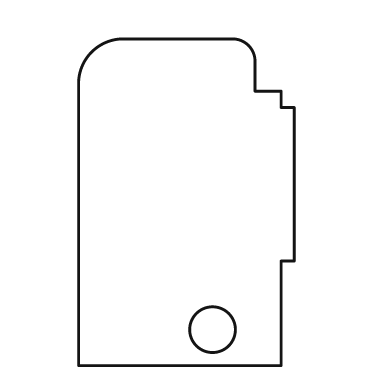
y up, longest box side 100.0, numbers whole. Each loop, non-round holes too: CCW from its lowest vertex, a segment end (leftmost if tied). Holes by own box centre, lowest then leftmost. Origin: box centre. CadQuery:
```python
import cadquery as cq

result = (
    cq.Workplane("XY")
    .moveTo(-33.0, -50.0)
    .lineTo(29.0, -50.0)
    .lineTo(29.0, -18.0)
    .lineTo(33.0, -18.0)
    .lineTo(33.0, 29.0)
    .lineTo(29.0, 29.0)
    .lineTo(29.0, 34.0)
    .lineTo(21.0, 34.0)
    .lineTo(21.0, 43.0)
    .threePointArc((19.0, 48.0), (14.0, 50.0))
    .lineTo(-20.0, 50.0)
    .threePointArc((-29.0, 46.0), (-33.0, 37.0))
    .close()
    .moveTo(8.0, -39.0)
    .circle(7.0)
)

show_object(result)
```